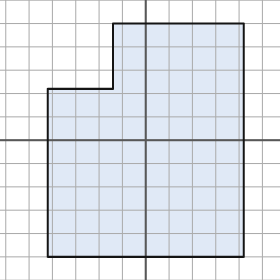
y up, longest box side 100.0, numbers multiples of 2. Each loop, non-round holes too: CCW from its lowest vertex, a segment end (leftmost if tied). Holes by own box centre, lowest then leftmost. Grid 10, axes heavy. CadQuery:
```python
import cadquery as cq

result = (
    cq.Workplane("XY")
    .moveTo(-42.0, -50.0)
    .lineTo(42.0, -50.0)
    .lineTo(42.0, 50.0)
    .lineTo(-14.0, 50.0)
    .lineTo(-14.0, 22.0)
    .lineTo(-42.0, 22.0)
    .close()
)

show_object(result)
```